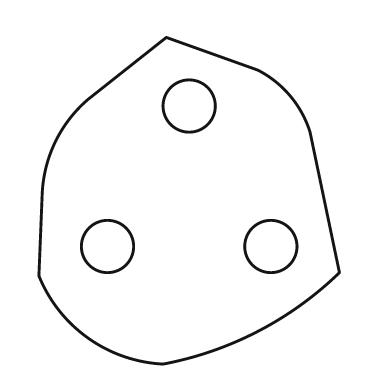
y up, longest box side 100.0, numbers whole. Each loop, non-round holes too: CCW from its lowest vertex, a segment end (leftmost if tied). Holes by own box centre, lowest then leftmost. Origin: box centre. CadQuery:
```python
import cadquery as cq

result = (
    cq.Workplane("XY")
    .moveTo(-8.0, -50.0)
    .threePointArc((21.0, -40.0), (46.0, -22.0))
    .lineTo(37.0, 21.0)
    .threePointArc((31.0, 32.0), (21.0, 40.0))
    .lineTo(-7.0, 50.0)
    .lineTo(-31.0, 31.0)
    .threePointArc((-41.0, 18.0), (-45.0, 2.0))
    .lineTo(-46.0, -23.0)
    .threePointArc((-31.0, -42.0), (-8.0, -50.0))
    .close()
    .moveTo(-25.0, -14.0)
    .circle(8.0)
    .moveTo(25.0, -14.0)
    .circle(8.0)
    .moveTo(0.0, 29.0)
    .circle(8.0)
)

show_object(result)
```